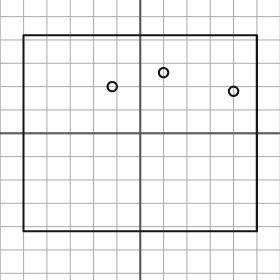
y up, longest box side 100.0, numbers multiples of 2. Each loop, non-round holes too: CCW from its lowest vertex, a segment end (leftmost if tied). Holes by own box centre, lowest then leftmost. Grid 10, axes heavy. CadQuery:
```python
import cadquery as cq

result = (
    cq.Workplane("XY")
    .moveTo(-50.0, -42.0)
    .lineTo(50.0, -42.0)
    .lineTo(50.0, 42.0)
    .lineTo(-50.0, 42.0)
    .close()
    .moveTo(40.0, 18.0)
    .circle(2.0)
    .moveTo(-12.0, 20.0)
    .circle(2.0)
    .moveTo(10.0, 26.0)
    .circle(2.0)
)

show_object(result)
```